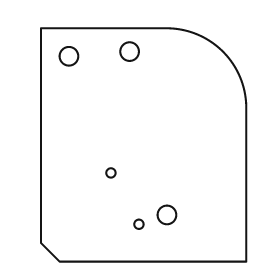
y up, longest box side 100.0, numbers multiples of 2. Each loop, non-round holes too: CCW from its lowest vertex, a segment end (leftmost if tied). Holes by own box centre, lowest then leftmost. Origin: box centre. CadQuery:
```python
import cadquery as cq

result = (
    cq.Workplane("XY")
    .moveTo(-36.0, -50.0)
    .lineTo(44.0, -50.0)
    .lineTo(44.0, 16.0)
    .threePointArc((34.0, 40.0), (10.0, 50.0))
    .lineTo(-44.0, 50.0)
    .lineTo(-44.0, -42.0)
    .close()
    .moveTo(-2.0, -34.0)
    .circle(2.0)
    .moveTo(10.0, -30.0)
    .circle(4.0)
    .moveTo(-14.0, -12.0)
    .circle(2.0)
    .moveTo(-32.0, 38.0)
    .circle(4.0)
    .moveTo(-6.0, 40.0)
    .circle(4.0)
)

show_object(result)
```